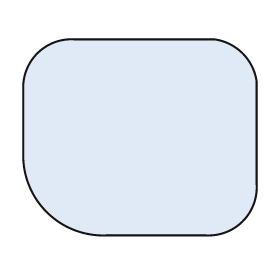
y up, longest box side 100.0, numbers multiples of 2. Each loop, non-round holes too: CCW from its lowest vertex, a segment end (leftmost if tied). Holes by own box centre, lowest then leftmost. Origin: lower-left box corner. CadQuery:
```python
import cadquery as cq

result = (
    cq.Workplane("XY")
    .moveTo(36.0, 0.0)
    .lineTo(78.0, 0.0)
    .threePointArc((94.0, 6.0), (100.0, 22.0))
    .lineTo(100.0, 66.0)
    .threePointArc((94.0, 78.0), (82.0, 84.0))
    .lineTo(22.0, 84.0)
    .threePointArc((6.0, 78.0), (0.0, 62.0))
    .lineTo(0.0, 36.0)
    .threePointArc((10.0, 10.0), (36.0, 0.0))
    .close()
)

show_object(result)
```